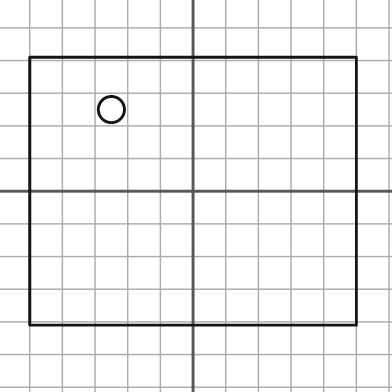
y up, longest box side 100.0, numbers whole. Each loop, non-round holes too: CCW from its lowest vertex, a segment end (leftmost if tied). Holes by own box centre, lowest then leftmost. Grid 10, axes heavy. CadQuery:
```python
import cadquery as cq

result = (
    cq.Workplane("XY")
    .moveTo(-50.0, -41.0)
    .lineTo(50.0, -41.0)
    .lineTo(50.0, 41.0)
    .lineTo(-50.0, 41.0)
    .close()
    .moveTo(-25.0, 25.0)
    .circle(4.0)
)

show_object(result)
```